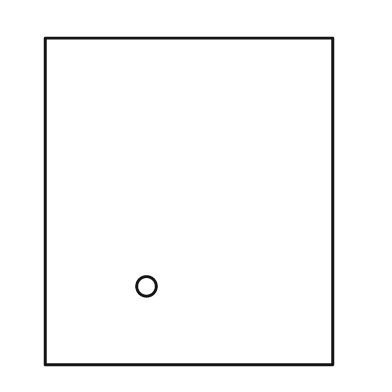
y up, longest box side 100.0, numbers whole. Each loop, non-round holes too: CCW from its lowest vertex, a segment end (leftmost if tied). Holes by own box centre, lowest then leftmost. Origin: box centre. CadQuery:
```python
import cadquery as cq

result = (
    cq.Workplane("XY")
    .moveTo(-44.0, -50.0)
    .lineTo(44.0, -50.0)
    .lineTo(44.0, 50.0)
    .lineTo(-44.0, 50.0)
    .close()
    .moveTo(-13.0, -26.0)
    .circle(3.0)
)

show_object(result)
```